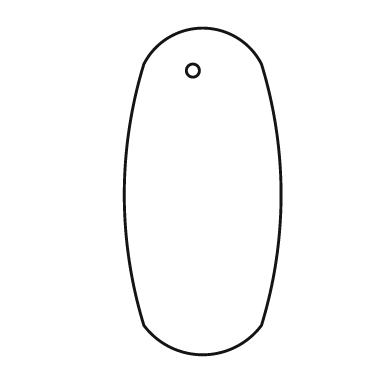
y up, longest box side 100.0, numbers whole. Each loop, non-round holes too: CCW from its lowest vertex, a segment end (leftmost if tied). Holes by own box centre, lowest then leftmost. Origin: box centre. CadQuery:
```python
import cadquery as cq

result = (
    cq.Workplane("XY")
    .moveTo(-18.0, -41.0)
    .threePointArc((0.0, -50.0), (18.0, -41.0))
    .threePointArc((24.0, -1.0), (18.0, 39.0))
    .threePointArc((0.0, 50.0), (-18.0, 39.0))
    .threePointArc((-24.0, -1.0), (-18.0, -41.0))
    .close()
    .moveTo(-3.0, 37.0)
    .circle(2.0)
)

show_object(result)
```